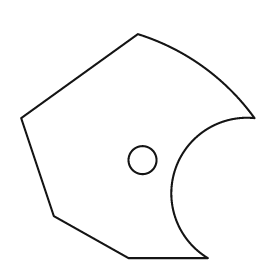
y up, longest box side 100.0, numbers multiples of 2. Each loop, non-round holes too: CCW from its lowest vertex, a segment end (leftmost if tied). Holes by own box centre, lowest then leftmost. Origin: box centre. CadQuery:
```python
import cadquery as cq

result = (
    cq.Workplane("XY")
    .moveTo(-4.0, -48.0)
    .lineTo(30.0, -48.0)
    .threePointArc((16.0, -10.0), (50.0, 12.0))
    .threePointArc((28.0, 34.0), (0.0, 48.0))
    .lineTo(-50.0, 12.0)
    .lineTo(-36.0, -30.0)
    .close()
    .moveTo(2.0, -6.0)
    .circle(6.0)
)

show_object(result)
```